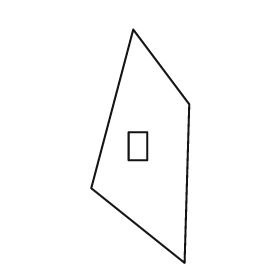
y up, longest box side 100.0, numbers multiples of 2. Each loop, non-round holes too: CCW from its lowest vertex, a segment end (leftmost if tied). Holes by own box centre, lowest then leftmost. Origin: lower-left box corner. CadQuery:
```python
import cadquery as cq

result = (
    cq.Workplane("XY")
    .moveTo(40.0, 0.0)
    .lineTo(42.0, 68.0)
    .lineTo(18.0, 100.0)
    .lineTo(0.0, 32.0)
    .close()
    .moveTo(16.0, 44.0)
    .lineTo(24.0, 44.0)
    .lineTo(24.0, 56.0)
    .lineTo(16.0, 56.0)
    .close()
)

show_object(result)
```